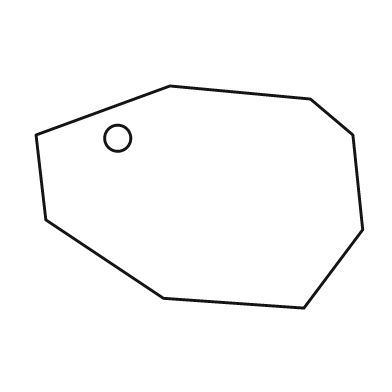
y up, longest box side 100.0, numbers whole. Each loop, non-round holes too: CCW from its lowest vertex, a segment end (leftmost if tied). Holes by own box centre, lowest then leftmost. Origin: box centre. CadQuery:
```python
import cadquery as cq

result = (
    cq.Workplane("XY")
    .moveTo(32.0, -34.0)
    .lineTo(50.0, -10.0)
    .lineTo(47.0, 19.0)
    .lineTo(34.0, 30.0)
    .lineTo(-9.0, 34.0)
    .lineTo(-50.0, 19.0)
    .lineTo(-47.0, -7.0)
    .lineTo(-11.0, -31.0)
    .close()
    .moveTo(-25.0, 18.0)
    .circle(4.0)
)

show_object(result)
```